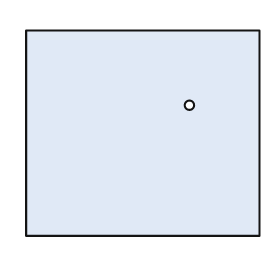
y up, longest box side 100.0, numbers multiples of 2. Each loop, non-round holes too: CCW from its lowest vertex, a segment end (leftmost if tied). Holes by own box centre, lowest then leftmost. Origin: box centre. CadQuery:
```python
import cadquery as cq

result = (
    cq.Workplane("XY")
    .moveTo(-50.0, -44.0)
    .lineTo(50.0, -44.0)
    .lineTo(50.0, 44.0)
    .lineTo(-50.0, 44.0)
    .close()
    .moveTo(20.0, 12.0)
    .circle(2.0)
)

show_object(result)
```